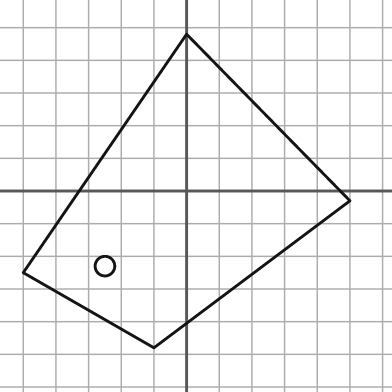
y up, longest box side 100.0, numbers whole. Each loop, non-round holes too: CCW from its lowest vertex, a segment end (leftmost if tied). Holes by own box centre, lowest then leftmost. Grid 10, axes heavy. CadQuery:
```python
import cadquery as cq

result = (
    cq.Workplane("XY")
    .moveTo(-10.0, -48.0)
    .lineTo(50.0, -3.0)
    .lineTo(0.0, 48.0)
    .lineTo(-50.0, -25.0)
    .close()
    .moveTo(-25.0, -23.0)
    .circle(3.0)
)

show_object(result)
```